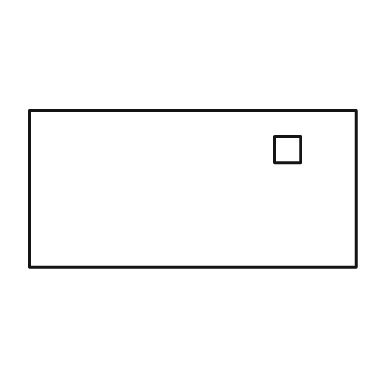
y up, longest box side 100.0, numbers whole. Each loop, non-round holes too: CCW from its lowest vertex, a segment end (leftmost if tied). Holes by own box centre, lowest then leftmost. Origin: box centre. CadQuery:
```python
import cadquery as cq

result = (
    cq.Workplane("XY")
    .moveTo(-50.0, -24.0)
    .lineTo(50.0, -24.0)
    .lineTo(50.0, 24.0)
    .lineTo(-50.0, 24.0)
    .close()
    .moveTo(25.0, 8.0)
    .lineTo(33.0, 8.0)
    .lineTo(33.0, 16.0)
    .lineTo(25.0, 16.0)
    .close()
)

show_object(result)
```